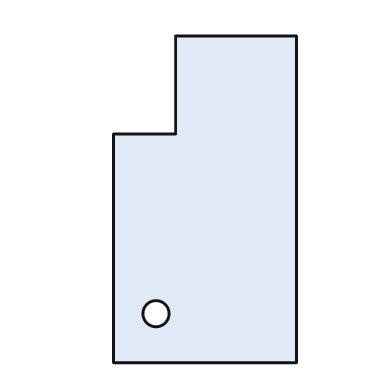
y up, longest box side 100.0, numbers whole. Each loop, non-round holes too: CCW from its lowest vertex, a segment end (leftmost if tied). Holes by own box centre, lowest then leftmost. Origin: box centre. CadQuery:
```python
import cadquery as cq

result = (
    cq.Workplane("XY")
    .moveTo(-28.0, -50.0)
    .lineTo(28.0, -50.0)
    .lineTo(28.0, 50.0)
    .lineTo(-9.0, 50.0)
    .lineTo(-9.0, 20.0)
    .lineTo(-28.0, 20.0)
    .close()
    .moveTo(-15.0, -35.0)
    .circle(4.0)
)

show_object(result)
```